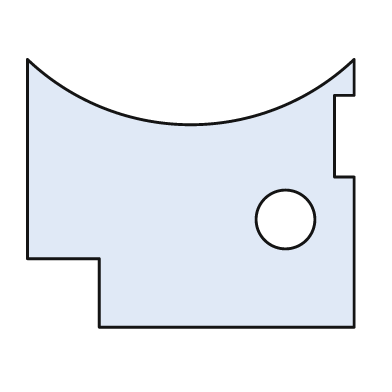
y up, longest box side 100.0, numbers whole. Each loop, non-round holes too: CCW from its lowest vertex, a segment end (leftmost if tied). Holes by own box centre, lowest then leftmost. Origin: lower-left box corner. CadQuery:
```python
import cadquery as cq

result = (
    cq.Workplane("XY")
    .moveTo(22.0, 0.0)
    .lineTo(100.0, 0.0)
    .lineTo(100.0, 46.0)
    .lineTo(94.0, 46.0)
    .lineTo(94.0, 71.0)
    .lineTo(100.0, 71.0)
    .lineTo(100.0, 82.0)
    .threePointArc((50.0, 62.0), (0.0, 82.0))
    .lineTo(0.0, 21.0)
    .lineTo(22.0, 21.0)
    .close()
    .moveTo(79.0, 33.0)
    .circle(9.0)
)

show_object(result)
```